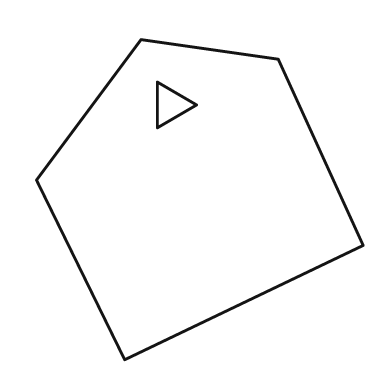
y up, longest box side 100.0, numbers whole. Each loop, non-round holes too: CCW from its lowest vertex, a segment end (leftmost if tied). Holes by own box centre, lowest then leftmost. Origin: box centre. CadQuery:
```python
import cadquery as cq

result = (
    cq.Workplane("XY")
    .moveTo(-23.0, -49.0)
    .lineTo(50.0, -14.0)
    .lineTo(24.0, 43.0)
    .lineTo(-18.0, 49.0)
    .lineTo(-50.0, 6.0)
    .close()
    .moveTo(-13.0, 22.0)
    .lineTo(-1.0, 29.0)
    .lineTo(-13.0, 36.0)
    .close()
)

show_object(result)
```